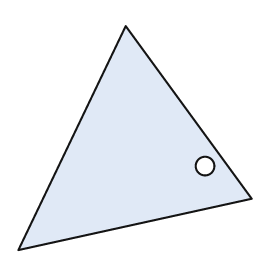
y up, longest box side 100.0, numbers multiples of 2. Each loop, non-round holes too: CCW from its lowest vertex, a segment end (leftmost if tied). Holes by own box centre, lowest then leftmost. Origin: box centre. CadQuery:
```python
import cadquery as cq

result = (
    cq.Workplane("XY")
    .moveTo(-50.0, -48.0)
    .lineTo(50.0, -26.0)
    .lineTo(-4.0, 48.0)
    .close()
    .moveTo(30.0, -12.0)
    .circle(4.0)
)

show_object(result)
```